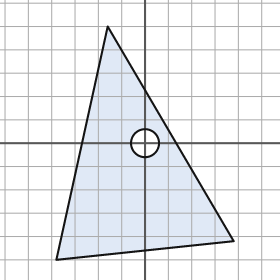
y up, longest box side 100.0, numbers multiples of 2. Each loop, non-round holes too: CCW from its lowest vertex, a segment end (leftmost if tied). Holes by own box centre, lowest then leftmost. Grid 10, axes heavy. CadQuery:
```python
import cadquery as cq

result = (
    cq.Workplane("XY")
    .moveTo(-38.0, -50.0)
    .lineTo(38.0, -42.0)
    .lineTo(-16.0, 50.0)
    .close()
    .moveTo(0.0, 0.0)
    .circle(6.0)
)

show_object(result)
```